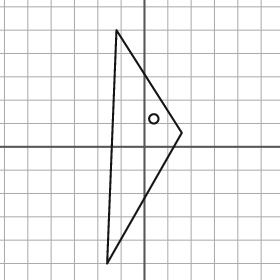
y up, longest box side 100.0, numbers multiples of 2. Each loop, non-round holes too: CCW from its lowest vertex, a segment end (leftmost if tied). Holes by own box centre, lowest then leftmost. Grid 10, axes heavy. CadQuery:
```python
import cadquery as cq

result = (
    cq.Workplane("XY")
    .moveTo(-16.0, -50.0)
    .lineTo(16.0, 6.0)
    .lineTo(-12.0, 50.0)
    .close()
    .moveTo(4.0, 12.0)
    .circle(2.0)
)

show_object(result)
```